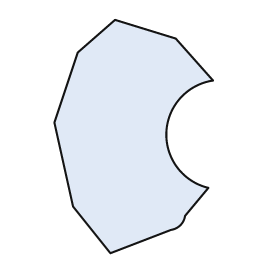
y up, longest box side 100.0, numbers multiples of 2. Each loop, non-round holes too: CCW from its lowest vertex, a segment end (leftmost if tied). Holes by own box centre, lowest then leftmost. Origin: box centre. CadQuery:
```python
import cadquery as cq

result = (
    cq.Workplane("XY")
    .moveTo(-10.0, -50.0)
    .lineTo(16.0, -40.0)
    .threePointArc((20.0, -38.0), (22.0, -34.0))
    .lineTo(32.0, -22.0)
    .threePointArc((14.0, 2.0), (34.0, 24.0))
    .lineTo(18.0, 42.0)
    .lineTo(-8.0, 50.0)
    .lineTo(-24.0, 36.0)
    .lineTo(-34.0, 6.0)
    .lineTo(-26.0, -30.0)
    .close()
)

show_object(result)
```